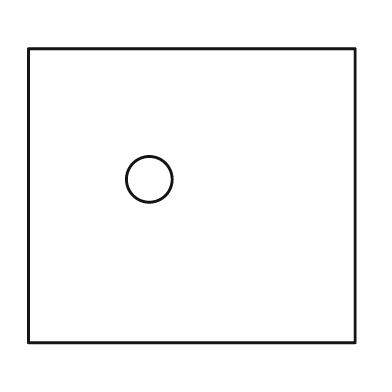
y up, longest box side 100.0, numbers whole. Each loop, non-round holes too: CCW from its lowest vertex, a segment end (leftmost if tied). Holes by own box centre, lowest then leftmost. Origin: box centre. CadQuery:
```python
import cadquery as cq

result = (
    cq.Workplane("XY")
    .moveTo(-50.0, -45.0)
    .lineTo(50.0, -45.0)
    .lineTo(50.0, 45.0)
    .lineTo(-50.0, 45.0)
    .close()
    .moveTo(-13.0, 5.0)
    .circle(7.0)
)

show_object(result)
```